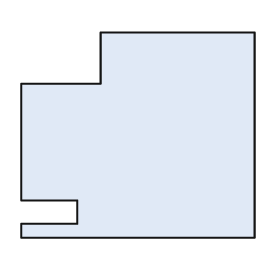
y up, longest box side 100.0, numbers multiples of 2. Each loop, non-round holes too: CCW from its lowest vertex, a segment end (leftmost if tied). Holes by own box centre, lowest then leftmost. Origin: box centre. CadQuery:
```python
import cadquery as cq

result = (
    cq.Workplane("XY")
    .moveTo(-50.0, -44.0)
    .lineTo(50.0, -44.0)
    .lineTo(50.0, 44.0)
    .lineTo(-16.0, 44.0)
    .lineTo(-16.0, 22.0)
    .lineTo(-50.0, 22.0)
    .lineTo(-50.0, -28.0)
    .lineTo(-26.0, -28.0)
    .lineTo(-26.0, -38.0)
    .lineTo(-50.0, -38.0)
    .close()
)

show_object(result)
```